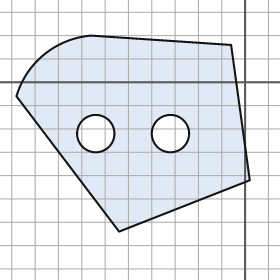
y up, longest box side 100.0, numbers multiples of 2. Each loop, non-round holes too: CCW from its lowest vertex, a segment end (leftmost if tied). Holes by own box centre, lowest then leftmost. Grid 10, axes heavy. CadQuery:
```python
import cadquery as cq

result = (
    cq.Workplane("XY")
    .moveTo(-54.0, -64.0)
    .lineTo(2.0, -42.0)
    .lineTo(-6.0, 16.0)
    .lineTo(-66.0, 20.0)
    .threePointArc((-86.0, 12.0), (-98.0, -6.0))
    .close()
    .moveTo(-64.0, -22.0)
    .circle(8.0)
    .moveTo(-32.0, -22.0)
    .circle(8.0)
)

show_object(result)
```